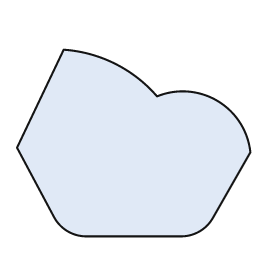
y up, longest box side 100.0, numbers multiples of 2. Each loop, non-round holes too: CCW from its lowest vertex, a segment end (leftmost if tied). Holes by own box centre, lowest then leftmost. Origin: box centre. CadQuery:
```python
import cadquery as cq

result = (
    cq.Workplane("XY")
    .moveTo(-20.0, -40.0)
    .lineTo(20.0, -40.0)
    .threePointArc((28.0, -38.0), (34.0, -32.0))
    .lineTo(50.0, -4.0)
    .threePointArc((36.0, 18.0), (10.0, 20.0))
    .threePointArc((-8.0, 34.0), (-30.0, 40.0))
    .lineTo(-50.0, -2.0)
    .lineTo(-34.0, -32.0)
    .threePointArc((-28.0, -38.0), (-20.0, -40.0))
    .close()
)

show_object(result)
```